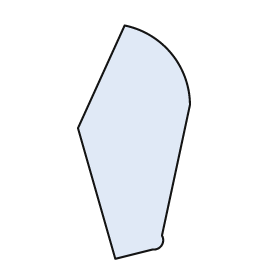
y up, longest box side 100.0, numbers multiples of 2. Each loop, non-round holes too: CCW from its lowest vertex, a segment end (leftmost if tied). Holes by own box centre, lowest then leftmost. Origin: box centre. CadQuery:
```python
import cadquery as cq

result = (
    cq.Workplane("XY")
    .moveTo(-8.0, -50.0)
    .lineTo(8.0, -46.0)
    .threePointArc((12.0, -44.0), (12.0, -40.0))
    .lineTo(24.0, 16.0)
    .threePointArc((16.0, 38.0), (-4.0, 50.0))
    .lineTo(-24.0, 6.0)
    .close()
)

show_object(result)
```